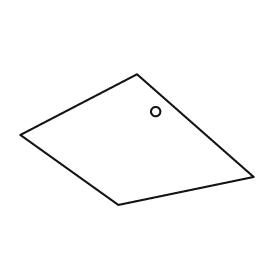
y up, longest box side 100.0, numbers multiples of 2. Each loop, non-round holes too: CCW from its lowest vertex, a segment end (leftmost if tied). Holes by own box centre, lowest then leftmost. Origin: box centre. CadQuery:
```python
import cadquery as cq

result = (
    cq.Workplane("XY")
    .moveTo(-8.0, -28.0)
    .lineTo(50.0, -16.0)
    .lineTo(0.0, 28.0)
    .lineTo(-50.0, 2.0)
    .close()
    .moveTo(8.0, 12.0)
    .circle(2.0)
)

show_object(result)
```